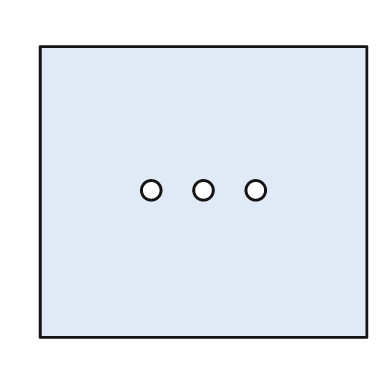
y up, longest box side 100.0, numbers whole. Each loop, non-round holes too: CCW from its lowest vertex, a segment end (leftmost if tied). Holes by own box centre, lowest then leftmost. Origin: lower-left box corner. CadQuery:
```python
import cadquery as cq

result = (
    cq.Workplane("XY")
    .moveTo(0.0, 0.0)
    .lineTo(100.0, 0.0)
    .lineTo(100.0, 89.0)
    .lineTo(0.0, 89.0)
    .close()
    .moveTo(34.0, 45.0)
    .circle(3.0)
    .moveTo(50.0, 45.0)
    .circle(3.0)
    .moveTo(66.0, 45.0)
    .circle(3.0)
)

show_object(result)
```